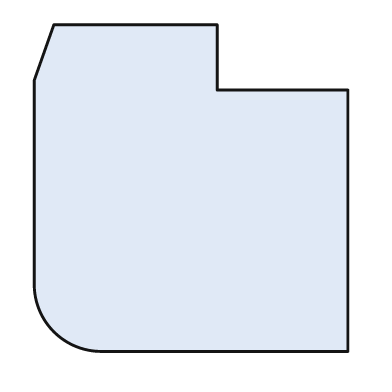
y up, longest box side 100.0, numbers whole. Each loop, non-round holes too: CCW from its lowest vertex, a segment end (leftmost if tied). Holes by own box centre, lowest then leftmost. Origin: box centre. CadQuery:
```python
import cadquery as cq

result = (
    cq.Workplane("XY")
    .moveTo(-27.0, -50.0)
    .lineTo(48.0, -50.0)
    .lineTo(48.0, 30.0)
    .lineTo(8.0, 30.0)
    .lineTo(8.0, 50.0)
    .lineTo(-42.0, 50.0)
    .lineTo(-48.0, 33.0)
    .lineTo(-48.0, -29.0)
    .threePointArc((-42.0, -44.0), (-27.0, -50.0))
    .close()
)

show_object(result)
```